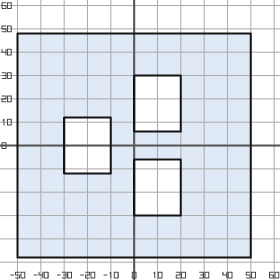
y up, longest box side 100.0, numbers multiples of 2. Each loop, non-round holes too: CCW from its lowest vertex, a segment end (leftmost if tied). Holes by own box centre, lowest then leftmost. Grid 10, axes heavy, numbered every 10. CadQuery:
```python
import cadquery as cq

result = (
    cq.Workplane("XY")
    .moveTo(-50.0, -48.0)
    .lineTo(50.0, -48.0)
    .lineTo(50.0, 48.0)
    .lineTo(-50.0, 48.0)
    .close()
    .moveTo(0.0, -30.0)
    .lineTo(20.0, -30.0)
    .lineTo(20.0, -6.0)
    .lineTo(0.0, -6.0)
    .close()
    .moveTo(-30.0, -12.0)
    .lineTo(-10.0, -12.0)
    .lineTo(-10.0, 12.0)
    .lineTo(-30.0, 12.0)
    .close()
    .moveTo(0.0, 6.0)
    .lineTo(20.0, 6.0)
    .lineTo(20.0, 30.0)
    .lineTo(0.0, 30.0)
    .close()
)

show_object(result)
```